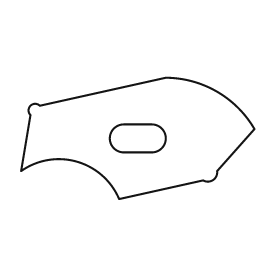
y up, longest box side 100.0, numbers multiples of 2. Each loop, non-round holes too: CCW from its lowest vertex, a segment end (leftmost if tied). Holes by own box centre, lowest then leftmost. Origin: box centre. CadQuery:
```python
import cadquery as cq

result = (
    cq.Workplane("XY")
    .moveTo(-8.0, -26.0)
    .lineTo(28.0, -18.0)
    .threePointArc((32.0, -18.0), (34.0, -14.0))
    .lineTo(50.0, 4.0)
    .threePointArc((34.0, 20.0), (12.0, 26.0))
    .lineTo(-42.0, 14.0)
    .threePointArc((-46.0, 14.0), (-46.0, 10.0))
    .lineTo(-50.0, -14.0)
    .threePointArc((-26.0, -10.0), (-8.0, -26.0))
    .close()
    .moveTo(-6.0, -6.0)
    .lineTo(6.0, -6.0)
    .threePointArc((12.0, 0.0), (6.0, 6.0))
    .lineTo(-6.0, 6.0)
    .threePointArc((-12.0, 0.0), (-6.0, -6.0))
    .close()
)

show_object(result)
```